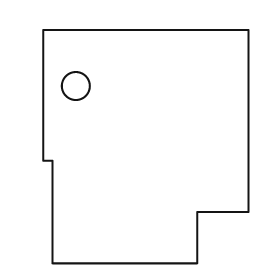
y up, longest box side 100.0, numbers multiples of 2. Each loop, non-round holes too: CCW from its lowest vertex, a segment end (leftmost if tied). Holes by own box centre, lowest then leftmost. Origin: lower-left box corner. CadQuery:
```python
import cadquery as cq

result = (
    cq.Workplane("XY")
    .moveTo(4.0, 0.0)
    .lineTo(66.0, 0.0)
    .lineTo(66.0, 22.0)
    .lineTo(88.0, 22.0)
    .lineTo(88.0, 100.0)
    .lineTo(0.0, 100.0)
    .lineTo(0.0, 44.0)
    .lineTo(4.0, 44.0)
    .close()
    .moveTo(14.0, 76.0)
    .circle(6.0)
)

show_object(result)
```